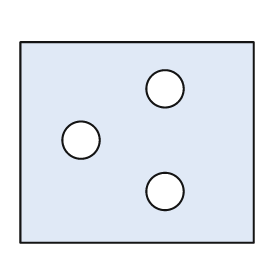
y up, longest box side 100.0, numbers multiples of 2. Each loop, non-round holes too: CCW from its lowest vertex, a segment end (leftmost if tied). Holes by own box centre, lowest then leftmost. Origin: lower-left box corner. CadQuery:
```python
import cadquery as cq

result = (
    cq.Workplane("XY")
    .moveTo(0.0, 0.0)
    .lineTo(100.0, 0.0)
    .lineTo(100.0, 86.0)
    .lineTo(0.0, 86.0)
    .close()
    .moveTo(62.0, 22.0)
    .circle(8.0)
    .moveTo(26.0, 44.0)
    .circle(8.0)
    .moveTo(62.0, 66.0)
    .circle(8.0)
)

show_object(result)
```